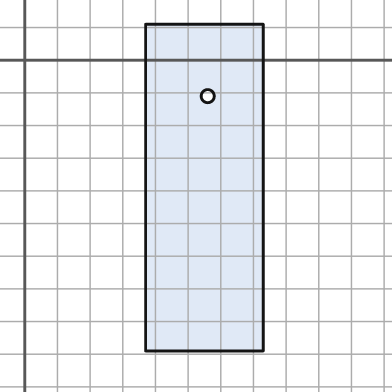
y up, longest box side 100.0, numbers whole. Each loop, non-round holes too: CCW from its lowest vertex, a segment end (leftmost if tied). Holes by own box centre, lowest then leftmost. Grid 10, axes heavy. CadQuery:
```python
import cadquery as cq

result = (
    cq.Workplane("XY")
    .moveTo(37.0, -89.0)
    .lineTo(73.0, -89.0)
    .lineTo(73.0, 11.0)
    .lineTo(37.0, 11.0)
    .close()
    .moveTo(56.0, -11.0)
    .circle(2.0)
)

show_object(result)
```